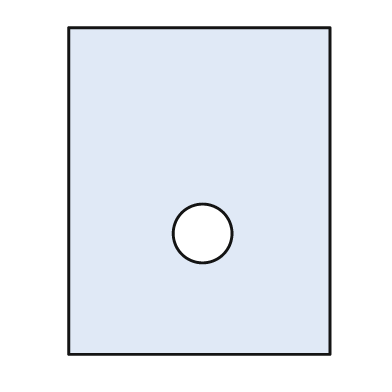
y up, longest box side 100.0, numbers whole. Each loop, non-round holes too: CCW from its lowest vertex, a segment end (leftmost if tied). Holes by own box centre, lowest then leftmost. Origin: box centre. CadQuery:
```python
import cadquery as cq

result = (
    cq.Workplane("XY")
    .moveTo(-40.0, -50.0)
    .lineTo(40.0, -50.0)
    .lineTo(40.0, 50.0)
    .lineTo(-40.0, 50.0)
    .close()
    .moveTo(1.0, -13.0)
    .circle(9.0)
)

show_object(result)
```